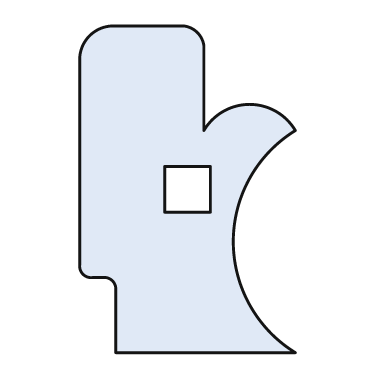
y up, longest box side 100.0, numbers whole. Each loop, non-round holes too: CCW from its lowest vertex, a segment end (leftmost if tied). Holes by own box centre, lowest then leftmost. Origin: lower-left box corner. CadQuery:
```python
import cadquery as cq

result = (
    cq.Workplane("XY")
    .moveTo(11.0, 0.0)
    .lineTo(66.0, 0.0)
    .threePointArc((47.0, 34.0), (66.0, 68.0))
    .threePointArc((52.0, 76.0), (38.0, 68.0))
    .lineTo(38.0, 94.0)
    .threePointArc((36.0, 98.0), (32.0, 100.0))
    .lineTo(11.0, 100.0)
    .threePointArc((3.0, 97.0), (0.0, 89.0))
    .lineTo(0.0, 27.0)
    .threePointArc((1.0, 24.0), (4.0, 23.0))
    .lineTo(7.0, 23.0)
    .threePointArc((10.0, 22.0), (11.0, 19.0))
    .close()
    .moveTo(26.0, 43.0)
    .lineTo(40.0, 43.0)
    .lineTo(40.0, 57.0)
    .lineTo(26.0, 57.0)
    .close()
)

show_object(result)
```